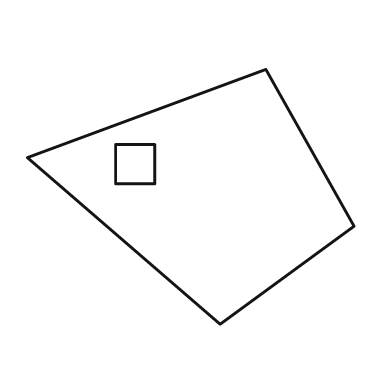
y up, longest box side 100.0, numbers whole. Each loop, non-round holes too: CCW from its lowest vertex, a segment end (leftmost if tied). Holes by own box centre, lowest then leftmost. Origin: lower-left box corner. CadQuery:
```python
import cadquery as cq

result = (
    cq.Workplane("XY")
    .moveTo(59.0, 0.0)
    .lineTo(100.0, 30.0)
    .lineTo(73.0, 78.0)
    .lineTo(0.0, 51.0)
    .close()
    .moveTo(27.0, 43.0)
    .lineTo(39.0, 43.0)
    .lineTo(39.0, 55.0)
    .lineTo(27.0, 55.0)
    .close()
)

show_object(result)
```